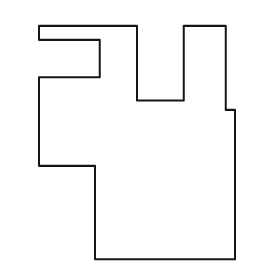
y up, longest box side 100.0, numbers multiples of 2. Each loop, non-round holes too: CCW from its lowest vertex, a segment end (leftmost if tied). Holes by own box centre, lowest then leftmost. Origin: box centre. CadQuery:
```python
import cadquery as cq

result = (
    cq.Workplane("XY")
    .moveTo(-18.0, -50.0)
    .lineTo(42.0, -50.0)
    .lineTo(42.0, 14.0)
    .lineTo(38.0, 14.0)
    .lineTo(38.0, 50.0)
    .lineTo(20.0, 50.0)
    .lineTo(20.0, 18.0)
    .lineTo(0.0, 18.0)
    .lineTo(0.0, 50.0)
    .lineTo(-42.0, 50.0)
    .lineTo(-42.0, 44.0)
    .lineTo(-16.0, 44.0)
    .lineTo(-16.0, 28.0)
    .lineTo(-42.0, 28.0)
    .lineTo(-42.0, -10.0)
    .lineTo(-18.0, -10.0)
    .close()
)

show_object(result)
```